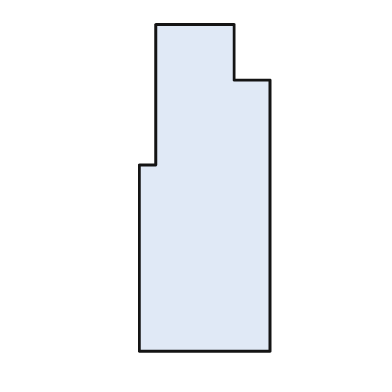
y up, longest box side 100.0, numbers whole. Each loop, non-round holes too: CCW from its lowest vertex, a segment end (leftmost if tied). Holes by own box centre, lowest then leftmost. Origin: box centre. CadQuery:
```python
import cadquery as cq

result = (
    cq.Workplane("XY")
    .moveTo(-20.0, -50.0)
    .lineTo(20.0, -50.0)
    .lineTo(20.0, 33.0)
    .lineTo(9.0, 33.0)
    .lineTo(9.0, 50.0)
    .lineTo(-15.0, 50.0)
    .lineTo(-15.0, 7.0)
    .lineTo(-20.0, 7.0)
    .close()
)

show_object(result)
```